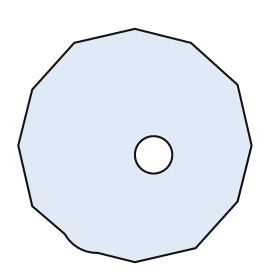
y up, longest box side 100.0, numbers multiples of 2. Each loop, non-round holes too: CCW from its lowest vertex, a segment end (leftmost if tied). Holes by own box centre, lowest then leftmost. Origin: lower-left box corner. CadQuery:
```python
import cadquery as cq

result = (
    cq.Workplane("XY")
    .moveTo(50.0, 0.0)
    .lineTo(76.0, 6.0)
    .lineTo(94.0, 26.0)
    .lineTo(100.0, 50.0)
    .lineTo(94.0, 76.0)
    .lineTo(74.0, 94.0)
    .lineTo(50.0, 100.0)
    .lineTo(24.0, 94.0)
    .lineTo(6.0, 74.0)
    .lineTo(0.0, 50.0)
    .lineTo(6.0, 24.0)
    .lineTo(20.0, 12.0)
    .threePointArc((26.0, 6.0), (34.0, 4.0))
    .close()
    .moveTo(58.0, 46.0)
    .circle(8.0)
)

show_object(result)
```